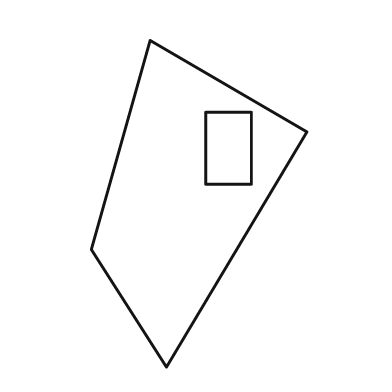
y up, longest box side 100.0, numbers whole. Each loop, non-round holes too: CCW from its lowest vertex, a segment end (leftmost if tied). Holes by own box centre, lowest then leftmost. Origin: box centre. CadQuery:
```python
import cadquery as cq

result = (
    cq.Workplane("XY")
    .moveTo(-10.0, -50.0)
    .lineTo(33.0, 22.0)
    .lineTo(-15.0, 50.0)
    .lineTo(-33.0, -14.0)
    .close()
    .moveTo(2.0, 6.0)
    .lineTo(16.0, 6.0)
    .lineTo(16.0, 28.0)
    .lineTo(2.0, 28.0)
    .close()
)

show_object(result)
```